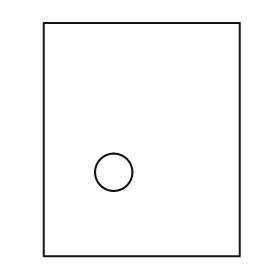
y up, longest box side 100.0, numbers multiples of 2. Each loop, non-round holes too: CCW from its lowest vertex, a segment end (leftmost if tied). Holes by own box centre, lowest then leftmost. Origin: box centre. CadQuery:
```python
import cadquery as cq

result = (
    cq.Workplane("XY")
    .moveTo(-42.0, -50.0)
    .lineTo(42.0, -50.0)
    .lineTo(42.0, 50.0)
    .lineTo(-42.0, 50.0)
    .close()
    .moveTo(-12.0, -14.0)
    .circle(8.0)
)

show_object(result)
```